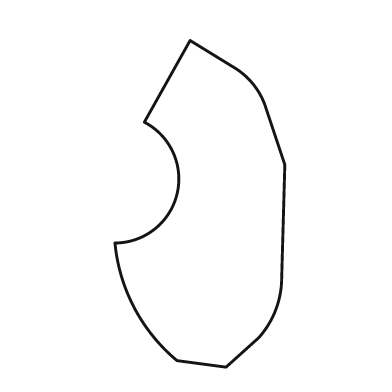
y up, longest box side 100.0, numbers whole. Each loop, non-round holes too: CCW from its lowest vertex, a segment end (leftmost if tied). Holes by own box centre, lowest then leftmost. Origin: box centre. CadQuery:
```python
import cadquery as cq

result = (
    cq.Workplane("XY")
    .moveTo(8.0, -50.0)
    .lineTo(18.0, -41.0)
    .threePointArc((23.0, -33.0), (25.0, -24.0))
    .lineTo(26.0, 12.0)
    .lineTo(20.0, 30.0)
    .threePointArc((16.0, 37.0), (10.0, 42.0))
    .lineTo(-3.0, 50.0)
    .lineTo(-17.0, 25.0)
    .threePointArc((-7.0, 3.0), (-26.0, -12.0))
    .threePointArc((-20.0, -32.0), (-7.0, -48.0))
    .close()
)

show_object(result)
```